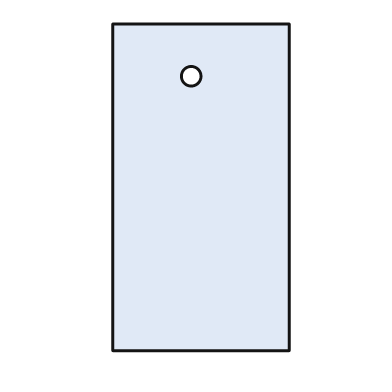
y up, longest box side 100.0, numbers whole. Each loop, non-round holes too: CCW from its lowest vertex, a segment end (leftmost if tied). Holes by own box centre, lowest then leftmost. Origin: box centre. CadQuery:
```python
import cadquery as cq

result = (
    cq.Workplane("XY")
    .moveTo(-27.0, -50.0)
    .lineTo(27.0, -50.0)
    .lineTo(27.0, 50.0)
    .lineTo(-27.0, 50.0)
    .close()
    .moveTo(-3.0, 34.0)
    .circle(3.0)
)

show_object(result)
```